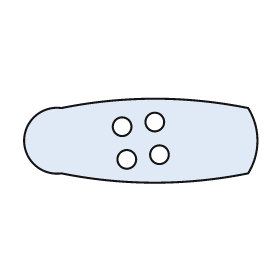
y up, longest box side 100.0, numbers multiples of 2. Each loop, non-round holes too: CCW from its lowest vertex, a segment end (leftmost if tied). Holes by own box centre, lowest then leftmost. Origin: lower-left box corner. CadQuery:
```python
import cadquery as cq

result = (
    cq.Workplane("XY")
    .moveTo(16.0, 4.0)
    .threePointArc((56.0, 0.0), (96.0, 4.0))
    .threePointArc((100.0, 18.0), (96.0, 32.0))
    .threePointArc((56.0, 36.0), (16.0, 32.0))
    .threePointArc((0.0, 18.0), (16.0, 4.0))
    .close()
    .moveTo(44.0, 10.0)
    .circle(4.0)
    .moveTo(58.0, 12.0)
    .circle(4.0)
    .moveTo(42.0, 24.0)
    .circle(4.0)
    .moveTo(56.0, 26.0)
    .circle(4.0)
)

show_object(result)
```